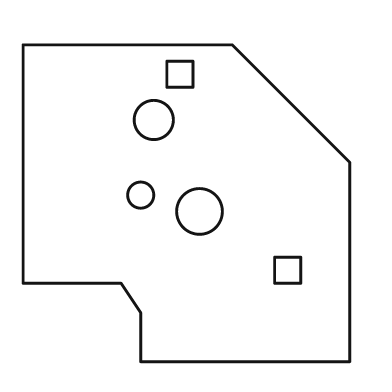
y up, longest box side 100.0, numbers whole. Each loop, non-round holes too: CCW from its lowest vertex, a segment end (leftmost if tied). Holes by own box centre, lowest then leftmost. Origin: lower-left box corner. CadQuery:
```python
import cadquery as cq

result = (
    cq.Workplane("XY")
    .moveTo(36.0, 0.0)
    .lineTo(100.0, 0.0)
    .lineTo(100.0, 61.0)
    .lineTo(64.0, 97.0)
    .lineTo(0.0, 97.0)
    .lineTo(0.0, 24.0)
    .lineTo(30.0, 24.0)
    .lineTo(36.0, 15.0)
    .close()
    .moveTo(77.0, 24.0)
    .lineTo(85.0, 24.0)
    .lineTo(85.0, 32.0)
    .lineTo(77.0, 32.0)
    .close()
    .moveTo(54.0, 46.0)
    .circle(7.0)
    .moveTo(36.0, 51.0)
    .circle(4.0)
    .moveTo(40.0, 74.0)
    .circle(6.0)
    .moveTo(44.0, 84.0)
    .lineTo(52.0, 84.0)
    .lineTo(52.0, 92.0)
    .lineTo(44.0, 92.0)
    .close()
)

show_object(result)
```